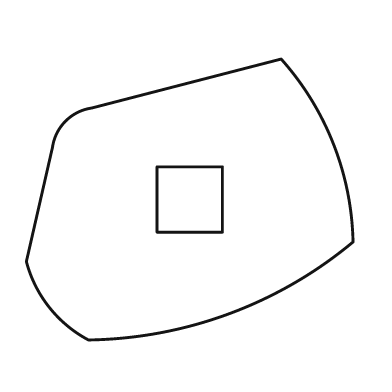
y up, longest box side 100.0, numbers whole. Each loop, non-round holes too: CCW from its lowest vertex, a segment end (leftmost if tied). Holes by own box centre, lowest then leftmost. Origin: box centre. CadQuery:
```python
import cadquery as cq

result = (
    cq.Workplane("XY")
    .moveTo(-31.0, -43.0)
    .threePointArc((12.0, -35.0), (50.0, -13.0))
    .threePointArc((44.0, 17.0), (28.0, 43.0))
    .lineTo(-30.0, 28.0)
    .threePointArc((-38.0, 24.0), (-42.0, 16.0))
    .lineTo(-50.0, -19.0)
    .threePointArc((-43.0, -33.0), (-31.0, -43.0))
    .close()
    .moveTo(-10.0, -10.0)
    .lineTo(10.0, -10.0)
    .lineTo(10.0, 10.0)
    .lineTo(-10.0, 10.0)
    .close()
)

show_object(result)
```